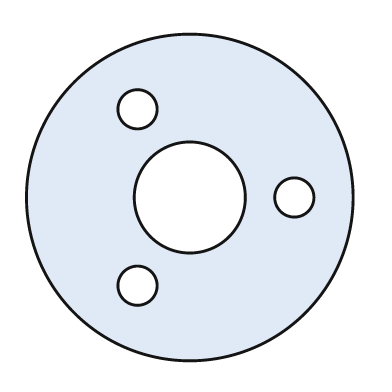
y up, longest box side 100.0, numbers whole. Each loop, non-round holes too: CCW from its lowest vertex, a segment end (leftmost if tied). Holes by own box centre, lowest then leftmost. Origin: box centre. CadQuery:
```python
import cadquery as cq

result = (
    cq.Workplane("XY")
    .moveTo(0.0, 0.0)
    .circle(50.0)
    .moveTo(-16.0, -27.0)
    .circle(6.0)
    .moveTo(0.0, 0.0)
    .circle(17.0)
    .moveTo(32.0, 0.0)
    .circle(6.0)
    .moveTo(-16.0, 27.0)
    .circle(6.0)
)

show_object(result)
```